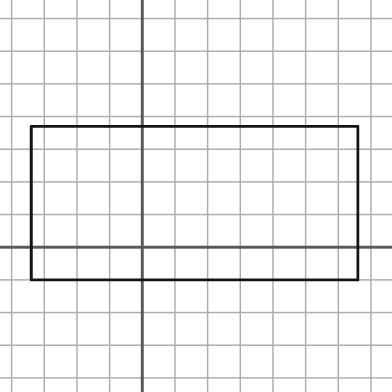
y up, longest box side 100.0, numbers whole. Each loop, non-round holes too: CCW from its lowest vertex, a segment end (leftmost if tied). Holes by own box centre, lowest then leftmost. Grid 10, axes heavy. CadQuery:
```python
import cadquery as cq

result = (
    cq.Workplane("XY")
    .moveTo(-34.0, -10.0)
    .lineTo(66.0, -10.0)
    .lineTo(66.0, 37.0)
    .lineTo(-34.0, 37.0)
    .close()
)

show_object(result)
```